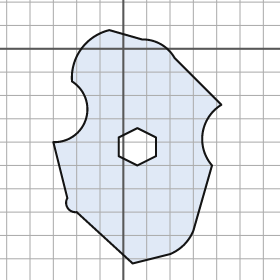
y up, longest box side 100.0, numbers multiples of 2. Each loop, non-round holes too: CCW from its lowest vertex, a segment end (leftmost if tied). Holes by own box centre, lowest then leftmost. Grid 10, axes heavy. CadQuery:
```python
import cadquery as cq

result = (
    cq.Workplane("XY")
    .moveTo(4.0, -92.0)
    .lineTo(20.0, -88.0)
    .threePointArc((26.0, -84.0), (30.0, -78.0))
    .lineTo(38.0, -50.0)
    .threePointArc((34.0, -36.0), (42.0, -24.0))
    .lineTo(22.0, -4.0)
    .threePointArc((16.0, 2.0), (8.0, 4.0))
    .lineTo(-6.0, 8.0)
    .threePointArc((-18.0, 0.0), (-22.0, -14.0))
    .threePointArc((-16.0, -30.0), (-30.0, -40.0))
    .lineTo(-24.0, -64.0)
    .threePointArc((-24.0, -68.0), (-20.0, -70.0))
    .close()
    .moveTo(6.0, -50.0)
    .lineTo(14.0, -46.0)
    .lineTo(14.0, -38.0)
    .lineTo(6.0, -34.0)
    .lineTo(-2.0, -38.0)
    .lineTo(-2.0, -46.0)
    .close()
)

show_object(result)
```